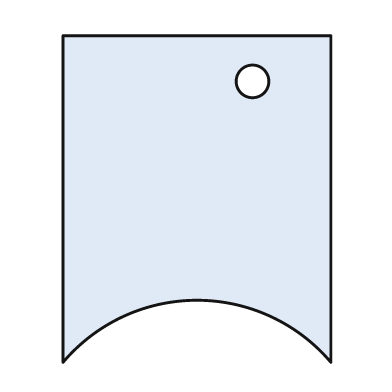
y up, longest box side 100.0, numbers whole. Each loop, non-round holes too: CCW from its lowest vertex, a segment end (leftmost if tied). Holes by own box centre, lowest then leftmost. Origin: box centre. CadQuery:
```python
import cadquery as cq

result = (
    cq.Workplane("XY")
    .moveTo(-41.0, -50.0)
    .threePointArc((0.0, -31.0), (41.0, -50.0))
    .lineTo(41.0, 50.0)
    .lineTo(-41.0, 50.0)
    .close()
    .moveTo(17.0, 36.0)
    .circle(5.0)
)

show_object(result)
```